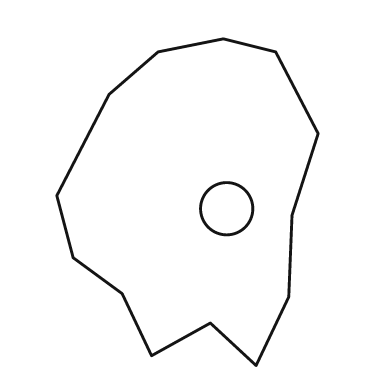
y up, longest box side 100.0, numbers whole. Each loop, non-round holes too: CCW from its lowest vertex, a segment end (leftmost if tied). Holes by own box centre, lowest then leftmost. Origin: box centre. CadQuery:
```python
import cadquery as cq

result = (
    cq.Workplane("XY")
    .moveTo(21.0, -50.0)
    .lineTo(31.0, -29.0)
    .lineTo(32.0, -4.0)
    .lineTo(40.0, 21.0)
    .lineTo(27.0, 46.0)
    .lineTo(11.0, 50.0)
    .lineTo(-9.0, 46.0)
    .lineTo(-24.0, 33.0)
    .lineTo(-40.0, 2.0)
    .lineTo(-35.0, -17.0)
    .lineTo(-20.0, -28.0)
    .lineTo(-11.0, -47.0)
    .lineTo(7.0, -37.0)
    .close()
    .moveTo(12.0, -2.0)
    .circle(8.0)
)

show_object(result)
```